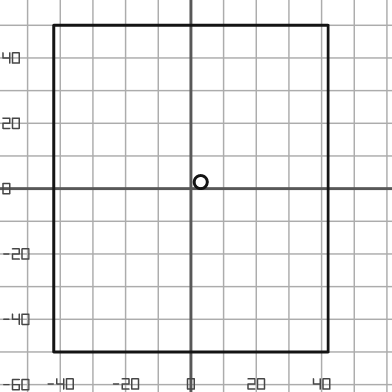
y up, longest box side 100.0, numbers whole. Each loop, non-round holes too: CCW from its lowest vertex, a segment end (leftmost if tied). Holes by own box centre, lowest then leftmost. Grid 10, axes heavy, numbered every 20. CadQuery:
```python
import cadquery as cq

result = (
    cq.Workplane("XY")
    .moveTo(-42.0, -50.0)
    .lineTo(42.0, -50.0)
    .lineTo(42.0, 50.0)
    .lineTo(-42.0, 50.0)
    .close()
    .moveTo(3.0, 2.0)
    .circle(2.0)
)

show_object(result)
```